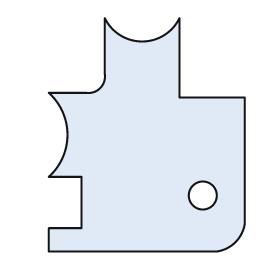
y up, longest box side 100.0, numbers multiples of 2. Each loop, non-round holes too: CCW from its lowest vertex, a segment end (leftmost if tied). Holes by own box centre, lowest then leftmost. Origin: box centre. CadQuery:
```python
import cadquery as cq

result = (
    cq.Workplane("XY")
    .moveTo(-42.0, -50.0)
    .lineTo(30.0, -50.0)
    .threePointArc((38.0, -46.0), (42.0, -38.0))
    .lineTo(42.0, 16.0)
    .lineTo(14.0, 16.0)
    .lineTo(14.0, 50.0)
    .threePointArc((-2.0, 40.0), (-18.0, 50.0))
    .lineTo(-18.0, 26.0)
    .threePointArc((-20.0, 20.0), (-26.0, 18.0))
    .lineTo(-42.0, 18.0)
    .threePointArc((-34.0, 0.0), (-42.0, -18.0))
    .lineTo(-28.0, -18.0)
    .lineTo(-28.0, -40.0)
    .lineTo(-42.0, -40.0)
    .close()
    .moveTo(24.0, -26.0)
    .circle(6.0)
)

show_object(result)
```